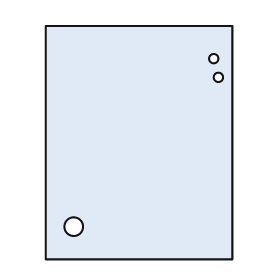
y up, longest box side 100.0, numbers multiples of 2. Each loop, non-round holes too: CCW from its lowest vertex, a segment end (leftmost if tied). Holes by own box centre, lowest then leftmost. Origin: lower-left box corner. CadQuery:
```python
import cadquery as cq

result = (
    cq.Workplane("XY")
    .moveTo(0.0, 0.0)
    .lineTo(80.0, 0.0)
    .lineTo(80.0, 100.0)
    .lineTo(0.0, 100.0)
    .close()
    .moveTo(12.0, 14.0)
    .circle(4.0)
    .moveTo(74.0, 78.0)
    .circle(2.0)
    .moveTo(72.0, 86.0)
    .circle(2.0)
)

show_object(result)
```